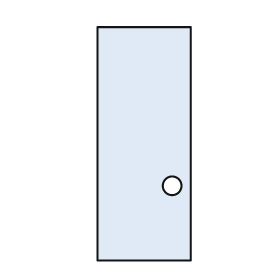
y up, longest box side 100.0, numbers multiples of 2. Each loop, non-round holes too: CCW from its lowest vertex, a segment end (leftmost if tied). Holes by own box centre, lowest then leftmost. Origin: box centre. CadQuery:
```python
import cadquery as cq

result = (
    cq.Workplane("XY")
    .moveTo(-20.0, -50.0)
    .lineTo(20.0, -50.0)
    .lineTo(20.0, 50.0)
    .lineTo(-20.0, 50.0)
    .close()
    .moveTo(12.0, -18.0)
    .circle(4.0)
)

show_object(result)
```